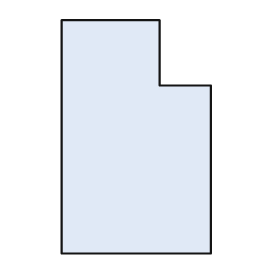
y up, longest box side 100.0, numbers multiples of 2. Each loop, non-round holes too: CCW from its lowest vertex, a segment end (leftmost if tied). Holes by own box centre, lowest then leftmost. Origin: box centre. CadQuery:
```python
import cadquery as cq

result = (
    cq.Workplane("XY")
    .moveTo(-32.0, -50.0)
    .lineTo(32.0, -50.0)
    .lineTo(32.0, 22.0)
    .lineTo(10.0, 22.0)
    .lineTo(10.0, 50.0)
    .lineTo(-32.0, 50.0)
    .close()
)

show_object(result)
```